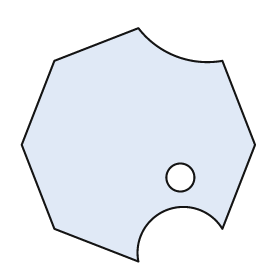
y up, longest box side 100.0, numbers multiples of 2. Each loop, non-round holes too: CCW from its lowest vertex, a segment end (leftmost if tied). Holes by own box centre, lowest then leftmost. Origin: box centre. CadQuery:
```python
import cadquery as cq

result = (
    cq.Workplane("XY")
    .moveTo(0.0, -50.0)
    .threePointArc((12.0, -28.0), (36.0, -36.0))
    .lineTo(50.0, 0.0)
    .lineTo(36.0, 36.0)
    .threePointArc((16.0, 38.0), (0.0, 50.0))
    .lineTo(-36.0, 36.0)
    .lineTo(-50.0, 0.0)
    .lineTo(-36.0, -36.0)
    .close()
    .moveTo(18.0, -14.0)
    .circle(6.0)
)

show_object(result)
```